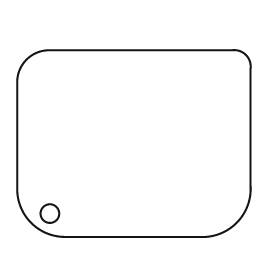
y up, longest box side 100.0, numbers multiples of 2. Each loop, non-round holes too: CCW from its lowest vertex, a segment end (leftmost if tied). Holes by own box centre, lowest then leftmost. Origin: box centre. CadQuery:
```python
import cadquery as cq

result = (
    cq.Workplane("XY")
    .moveTo(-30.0, -40.0)
    .lineTo(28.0, -40.0)
    .threePointArc((44.0, -34.0), (50.0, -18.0))
    .lineTo(50.0, 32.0)
    .threePointArc((48.0, 38.0), (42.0, 40.0))
    .lineTo(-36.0, 40.0)
    .threePointArc((-46.0, 36.0), (-50.0, 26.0))
    .lineTo(-50.0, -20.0)
    .threePointArc((-44.0, -34.0), (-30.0, -40.0))
    .close()
    .moveTo(-36.0, -30.0)
    .circle(4.0)
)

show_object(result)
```